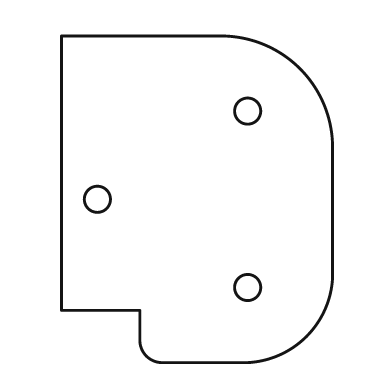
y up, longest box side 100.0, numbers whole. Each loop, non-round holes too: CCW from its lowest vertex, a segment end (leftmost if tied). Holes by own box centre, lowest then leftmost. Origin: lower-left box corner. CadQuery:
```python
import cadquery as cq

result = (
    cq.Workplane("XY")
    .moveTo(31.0, 0.0)
    .lineTo(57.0, 0.0)
    .threePointArc((75.0, 8.0), (83.0, 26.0))
    .lineTo(83.0, 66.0)
    .threePointArc((73.0, 90.0), (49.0, 100.0))
    .lineTo(0.0, 100.0)
    .lineTo(0.0, 16.0)
    .lineTo(24.0, 16.0)
    .lineTo(24.0, 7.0)
    .threePointArc((26.0, 2.0), (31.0, 0.0))
    .close()
    .moveTo(57.0, 23.0)
    .circle(4.0)
    .moveTo(11.0, 50.0)
    .circle(4.0)
    .moveTo(57.0, 77.0)
    .circle(4.0)
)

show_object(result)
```